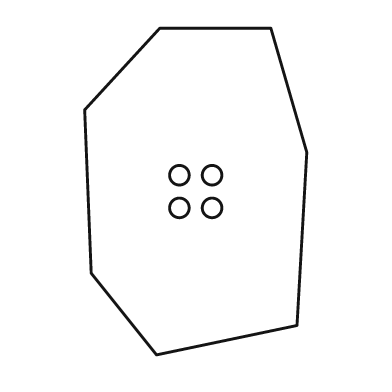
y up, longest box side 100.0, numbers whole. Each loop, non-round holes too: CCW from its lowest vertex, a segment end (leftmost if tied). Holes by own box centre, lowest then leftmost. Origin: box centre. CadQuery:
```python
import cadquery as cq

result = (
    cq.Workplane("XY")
    .moveTo(-12.0, -50.0)
    .lineTo(31.0, -41.0)
    .lineTo(34.0, 12.0)
    .lineTo(23.0, 50.0)
    .lineTo(-11.0, 50.0)
    .lineTo(-34.0, 25.0)
    .lineTo(-32.0, -25.0)
    .close()
    .moveTo(-5.0, -5.0)
    .circle(3.0)
    .moveTo(5.0, -5.0)
    .circle(3.0)
    .moveTo(-5.0, 5.0)
    .circle(3.0)
    .moveTo(5.0, 5.0)
    .circle(3.0)
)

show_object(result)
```